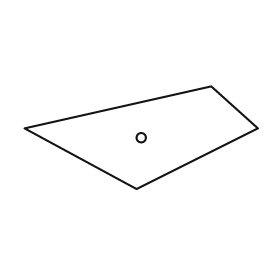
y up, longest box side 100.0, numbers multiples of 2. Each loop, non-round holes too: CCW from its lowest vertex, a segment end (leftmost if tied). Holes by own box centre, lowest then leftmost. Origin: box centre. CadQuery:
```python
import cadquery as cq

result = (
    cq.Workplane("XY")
    .moveTo(-2.0, -22.0)
    .lineTo(50.0, 4.0)
    .lineTo(30.0, 22.0)
    .lineTo(-50.0, 4.0)
    .close()
    .moveTo(0.0, 0.0)
    .circle(2.0)
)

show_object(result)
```